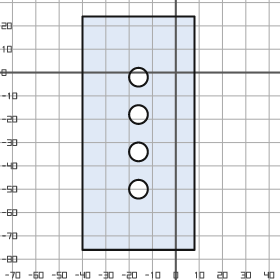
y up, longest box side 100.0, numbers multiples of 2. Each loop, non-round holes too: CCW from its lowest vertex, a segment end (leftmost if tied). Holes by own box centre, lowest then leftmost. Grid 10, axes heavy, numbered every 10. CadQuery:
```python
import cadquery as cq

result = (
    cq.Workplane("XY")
    .moveTo(-40.0, -76.0)
    .lineTo(8.0, -76.0)
    .lineTo(8.0, 24.0)
    .lineTo(-40.0, 24.0)
    .close()
    .moveTo(-16.0, -50.0)
    .circle(4.0)
    .moveTo(-16.0, -34.0)
    .circle(4.0)
    .moveTo(-16.0, -18.0)
    .circle(4.0)
    .moveTo(-16.0, -2.0)
    .circle(4.0)
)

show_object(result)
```